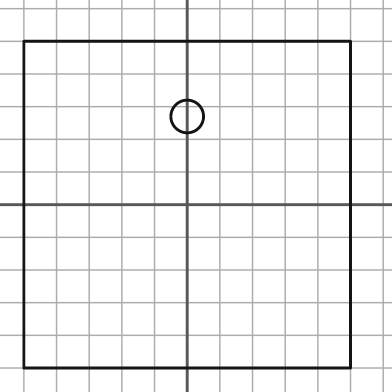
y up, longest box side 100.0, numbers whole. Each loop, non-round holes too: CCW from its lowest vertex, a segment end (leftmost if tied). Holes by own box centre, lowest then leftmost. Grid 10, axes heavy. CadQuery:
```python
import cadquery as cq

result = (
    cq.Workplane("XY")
    .moveTo(-50.0, -50.0)
    .lineTo(50.0, -50.0)
    .lineTo(50.0, 50.0)
    .lineTo(-50.0, 50.0)
    .close()
    .moveTo(0.0, 27.0)
    .circle(5.0)
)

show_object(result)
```